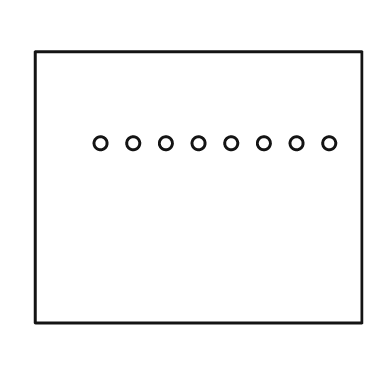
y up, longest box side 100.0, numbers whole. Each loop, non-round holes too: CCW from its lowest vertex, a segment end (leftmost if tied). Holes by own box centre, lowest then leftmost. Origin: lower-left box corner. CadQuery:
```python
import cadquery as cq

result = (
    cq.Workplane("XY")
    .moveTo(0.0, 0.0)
    .lineTo(100.0, 0.0)
    .lineTo(100.0, 83.0)
    .lineTo(0.0, 83.0)
    .close()
    .moveTo(20.0, 55.0)
    .circle(2.0)
    .moveTo(30.0, 55.0)
    .circle(2.0)
    .moveTo(40.0, 55.0)
    .circle(2.0)
    .moveTo(50.0, 55.0)
    .circle(2.0)
    .moveTo(60.0, 55.0)
    .circle(2.0)
    .moveTo(70.0, 55.0)
    .circle(2.0)
    .moveTo(80.0, 55.0)
    .circle(2.0)
    .moveTo(90.0, 55.0)
    .circle(2.0)
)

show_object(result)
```